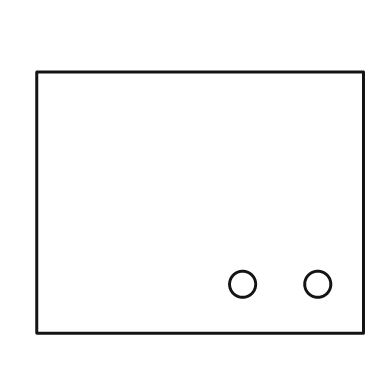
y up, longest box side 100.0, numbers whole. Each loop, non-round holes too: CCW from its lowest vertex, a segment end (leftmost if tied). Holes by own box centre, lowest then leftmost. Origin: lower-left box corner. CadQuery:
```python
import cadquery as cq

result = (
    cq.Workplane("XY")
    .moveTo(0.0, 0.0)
    .lineTo(100.0, 0.0)
    .lineTo(100.0, 80.0)
    .lineTo(0.0, 80.0)
    .close()
    .moveTo(63.0, 15.0)
    .circle(4.0)
    .moveTo(86.0, 15.0)
    .circle(4.0)
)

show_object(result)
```